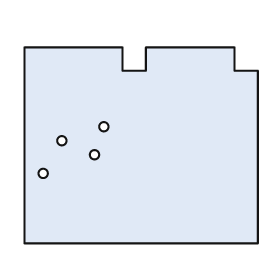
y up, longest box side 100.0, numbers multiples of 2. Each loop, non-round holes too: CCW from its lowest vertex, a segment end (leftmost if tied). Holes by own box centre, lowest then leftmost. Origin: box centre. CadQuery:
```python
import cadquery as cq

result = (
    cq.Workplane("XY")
    .moveTo(-50.0, -42.0)
    .lineTo(50.0, -42.0)
    .lineTo(50.0, 32.0)
    .lineTo(40.0, 32.0)
    .lineTo(40.0, 42.0)
    .lineTo(2.0, 42.0)
    .lineTo(2.0, 32.0)
    .lineTo(-8.0, 32.0)
    .lineTo(-8.0, 42.0)
    .lineTo(-50.0, 42.0)
    .close()
    .moveTo(-42.0, -12.0)
    .circle(2.0)
    .moveTo(-20.0, -4.0)
    .circle(2.0)
    .moveTo(-34.0, 2.0)
    .circle(2.0)
    .moveTo(-16.0, 8.0)
    .circle(2.0)
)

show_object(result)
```